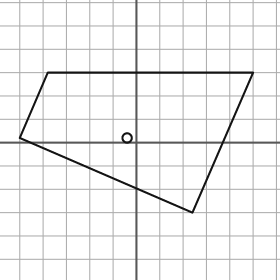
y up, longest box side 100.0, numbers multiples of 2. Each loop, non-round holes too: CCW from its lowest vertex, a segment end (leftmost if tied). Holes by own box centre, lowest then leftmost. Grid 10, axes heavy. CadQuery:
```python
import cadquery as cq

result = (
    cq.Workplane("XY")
    .moveTo(24.0, -30.0)
    .lineTo(50.0, 30.0)
    .lineTo(-38.0, 30.0)
    .lineTo(-50.0, 2.0)
    .close()
    .moveTo(-4.0, 2.0)
    .circle(2.0)
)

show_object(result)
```